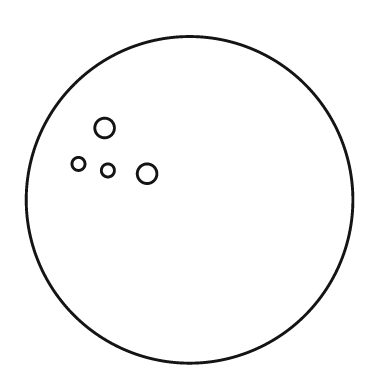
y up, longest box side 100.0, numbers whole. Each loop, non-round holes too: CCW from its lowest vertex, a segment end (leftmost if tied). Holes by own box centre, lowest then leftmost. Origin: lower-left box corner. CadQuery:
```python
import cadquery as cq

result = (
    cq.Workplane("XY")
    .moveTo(50.0, 50.0)
    .circle(50.0)
    .moveTo(37.0, 58.0)
    .circle(3.0)
    .moveTo(25.0, 59.0)
    .circle(2.0)
    .moveTo(16.0, 61.0)
    .circle(2.0)
    .moveTo(24.0, 72.0)
    .circle(3.0)
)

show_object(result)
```